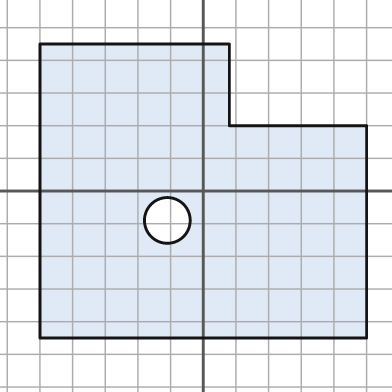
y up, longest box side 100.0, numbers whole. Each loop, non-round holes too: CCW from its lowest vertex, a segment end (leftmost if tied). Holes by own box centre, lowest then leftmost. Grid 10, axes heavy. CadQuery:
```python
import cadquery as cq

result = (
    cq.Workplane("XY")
    .moveTo(-50.0, -45.0)
    .lineTo(50.0, -45.0)
    .lineTo(50.0, 20.0)
    .lineTo(8.0, 20.0)
    .lineTo(8.0, 45.0)
    .lineTo(-50.0, 45.0)
    .close()
    .moveTo(-11.0, -9.0)
    .circle(7.0)
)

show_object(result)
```